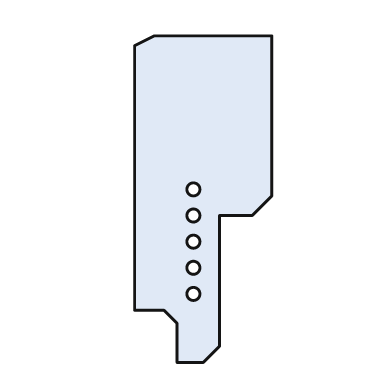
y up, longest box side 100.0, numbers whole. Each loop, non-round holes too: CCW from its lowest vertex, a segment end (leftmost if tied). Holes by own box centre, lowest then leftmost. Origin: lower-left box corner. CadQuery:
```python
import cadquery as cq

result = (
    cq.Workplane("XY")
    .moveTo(13.0, 0.0)
    .lineTo(21.0, 0.0)
    .lineTo(26.0, 5.0)
    .lineTo(26.0, 45.0)
    .lineTo(36.0, 45.0)
    .lineTo(42.0, 51.0)
    .lineTo(42.0, 100.0)
    .lineTo(6.0, 100.0)
    .lineTo(0.0, 97.0)
    .lineTo(0.0, 16.0)
    .lineTo(9.0, 16.0)
    .lineTo(13.0, 12.0)
    .close()
    .moveTo(18.0, 21.0)
    .circle(2.0)
    .moveTo(18.0, 29.0)
    .circle(2.0)
    .moveTo(18.0, 37.0)
    .circle(2.0)
    .moveTo(18.0, 45.0)
    .circle(2.0)
    .moveTo(18.0, 53.0)
    .circle(2.0)
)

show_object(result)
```